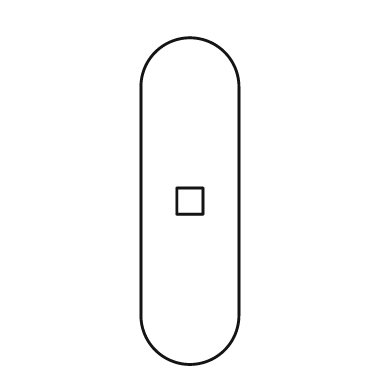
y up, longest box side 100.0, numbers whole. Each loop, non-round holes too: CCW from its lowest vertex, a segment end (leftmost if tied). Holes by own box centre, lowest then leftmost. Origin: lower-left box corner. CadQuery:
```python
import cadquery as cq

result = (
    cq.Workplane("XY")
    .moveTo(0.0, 15.0)
    .threePointArc((15.0, 0.0), (30.0, 15.0))
    .lineTo(30.0, 85.0)
    .threePointArc((15.0, 100.0), (0.0, 85.0))
    .close()
    .moveTo(11.0, 46.0)
    .lineTo(19.0, 46.0)
    .lineTo(19.0, 54.0)
    .lineTo(11.0, 54.0)
    .close()
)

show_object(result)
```